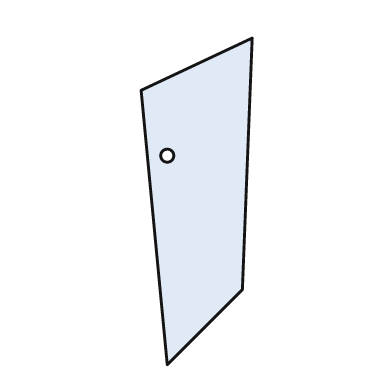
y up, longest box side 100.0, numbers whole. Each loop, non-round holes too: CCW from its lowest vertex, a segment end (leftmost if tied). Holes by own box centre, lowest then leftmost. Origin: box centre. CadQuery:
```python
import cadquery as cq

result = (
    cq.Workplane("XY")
    .moveTo(-9.0, -50.0)
    .lineTo(14.0, -27.0)
    .lineTo(17.0, 50.0)
    .lineTo(-17.0, 34.0)
    .close()
    .moveTo(-9.0, 14.0)
    .circle(2.0)
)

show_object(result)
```